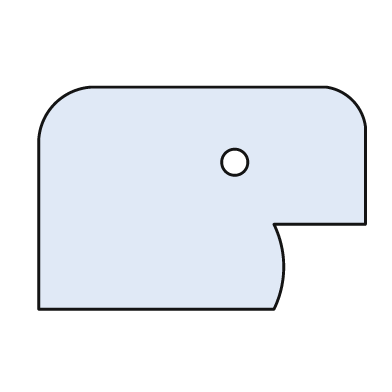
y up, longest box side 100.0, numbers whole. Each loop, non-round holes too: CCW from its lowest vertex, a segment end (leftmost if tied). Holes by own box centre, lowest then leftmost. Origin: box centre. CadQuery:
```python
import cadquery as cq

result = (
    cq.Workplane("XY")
    .moveTo(-50.0, -34.0)
    .lineTo(22.0, -34.0)
    .threePointArc((25.0, -21.0), (22.0, -8.0))
    .lineTo(50.0, -8.0)
    .lineTo(50.0, 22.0)
    .threePointArc((46.0, 30.0), (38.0, 34.0))
    .lineTo(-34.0, 34.0)
    .threePointArc((-45.0, 29.0), (-50.0, 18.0))
    .close()
    .moveTo(10.0, 11.0)
    .circle(4.0)
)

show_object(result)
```